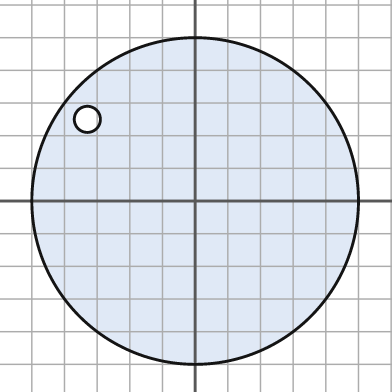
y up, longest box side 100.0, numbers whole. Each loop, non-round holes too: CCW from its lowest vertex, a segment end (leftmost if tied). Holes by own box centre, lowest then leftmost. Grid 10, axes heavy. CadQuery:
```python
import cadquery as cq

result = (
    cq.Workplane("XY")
    .moveTo(0.0, 0.0)
    .circle(50.0)
    .moveTo(-33.0, 25.0)
    .circle(4.0)
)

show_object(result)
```